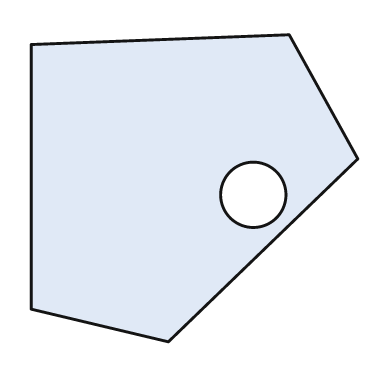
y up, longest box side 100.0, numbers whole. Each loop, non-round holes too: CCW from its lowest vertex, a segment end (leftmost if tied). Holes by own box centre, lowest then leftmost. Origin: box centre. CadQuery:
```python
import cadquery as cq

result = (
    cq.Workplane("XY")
    .moveTo(-8.0, -47.0)
    .lineTo(50.0, 9.0)
    .lineTo(29.0, 47.0)
    .lineTo(-50.0, 44.0)
    .lineTo(-50.0, -37.0)
    .close()
    .moveTo(18.0, -2.0)
    .circle(10.0)
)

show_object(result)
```